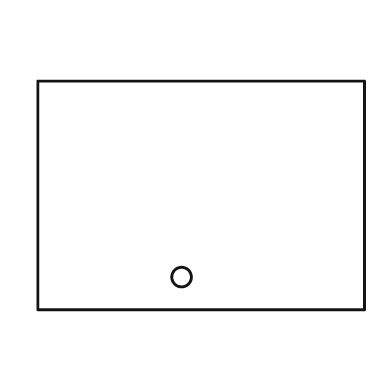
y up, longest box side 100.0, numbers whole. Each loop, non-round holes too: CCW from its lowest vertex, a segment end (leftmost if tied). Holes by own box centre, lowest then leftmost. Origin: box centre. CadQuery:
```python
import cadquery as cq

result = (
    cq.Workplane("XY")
    .moveTo(-50.0, -35.0)
    .lineTo(50.0, -35.0)
    .lineTo(50.0, 35.0)
    .lineTo(-50.0, 35.0)
    .close()
    .moveTo(-6.0, -25.0)
    .circle(3.0)
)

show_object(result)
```